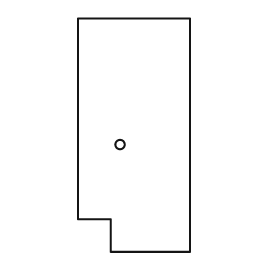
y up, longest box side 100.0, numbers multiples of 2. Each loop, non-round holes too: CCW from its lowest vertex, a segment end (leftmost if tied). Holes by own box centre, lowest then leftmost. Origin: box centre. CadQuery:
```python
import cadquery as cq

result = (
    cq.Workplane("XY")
    .moveTo(-10.0, -50.0)
    .lineTo(24.0, -50.0)
    .lineTo(24.0, 50.0)
    .lineTo(-24.0, 50.0)
    .lineTo(-24.0, -36.0)
    .lineTo(-10.0, -36.0)
    .close()
    .moveTo(-6.0, -4.0)
    .circle(2.0)
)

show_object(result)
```